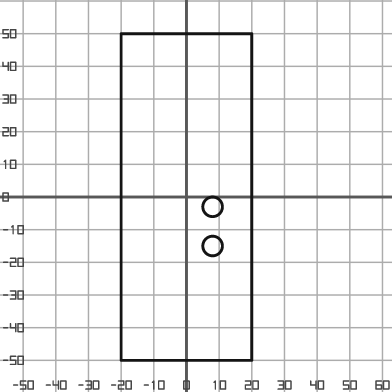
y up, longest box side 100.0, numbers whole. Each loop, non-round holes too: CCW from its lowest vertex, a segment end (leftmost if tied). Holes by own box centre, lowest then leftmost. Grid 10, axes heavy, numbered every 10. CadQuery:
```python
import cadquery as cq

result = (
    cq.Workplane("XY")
    .moveTo(-20.0, -50.0)
    .lineTo(20.0, -50.0)
    .lineTo(20.0, 50.0)
    .lineTo(-20.0, 50.0)
    .close()
    .moveTo(8.0, -15.0)
    .circle(3.0)
    .moveTo(8.0, -3.0)
    .circle(3.0)
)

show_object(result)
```